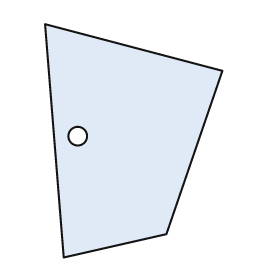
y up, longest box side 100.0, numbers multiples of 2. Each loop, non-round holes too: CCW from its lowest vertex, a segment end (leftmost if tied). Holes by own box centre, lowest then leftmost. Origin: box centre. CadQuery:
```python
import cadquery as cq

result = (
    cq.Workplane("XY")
    .moveTo(-30.0, -50.0)
    .lineTo(14.0, -40.0)
    .lineTo(38.0, 30.0)
    .lineTo(-38.0, 50.0)
    .close()
    .moveTo(-24.0, 2.0)
    .circle(4.0)
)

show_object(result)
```